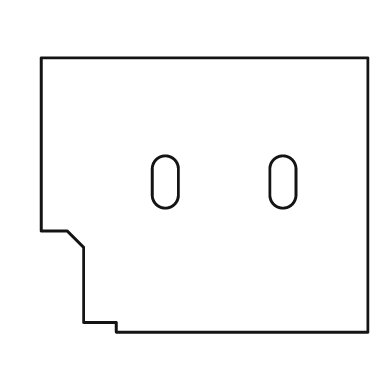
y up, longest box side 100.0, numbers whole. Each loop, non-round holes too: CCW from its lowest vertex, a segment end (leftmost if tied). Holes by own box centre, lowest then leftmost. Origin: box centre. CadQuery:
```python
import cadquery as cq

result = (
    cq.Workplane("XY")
    .moveTo(-27.0, -42.0)
    .lineTo(50.0, -42.0)
    .lineTo(50.0, 42.0)
    .lineTo(-50.0, 42.0)
    .lineTo(-50.0, -11.0)
    .lineTo(-42.0, -11.0)
    .lineTo(-37.0, -16.0)
    .lineTo(-37.0, -39.0)
    .lineTo(-27.0, -39.0)
    .close()
    .moveTo(-16.0, 0.0)
    .threePointArc((-12.0, -4.0), (-8.0, 0.0))
    .lineTo(-8.0, 8.0)
    .threePointArc((-12.0, 12.0), (-16.0, 8.0))
    .close()
    .moveTo(20.0, 0.0)
    .threePointArc((24.0, -4.0), (28.0, 0.0))
    .lineTo(28.0, 8.0)
    .threePointArc((24.0, 12.0), (20.0, 8.0))
    .close()
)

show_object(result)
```